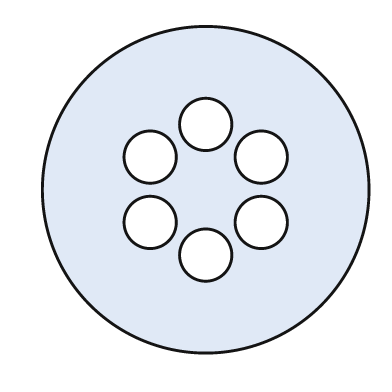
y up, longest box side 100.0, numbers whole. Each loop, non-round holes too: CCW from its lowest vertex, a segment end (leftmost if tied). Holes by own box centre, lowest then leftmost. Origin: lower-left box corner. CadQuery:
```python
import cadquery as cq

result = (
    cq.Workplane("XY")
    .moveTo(50.0, 50.0)
    .circle(50.0)
    .moveTo(50.0, 30.0)
    .circle(8.0)
    .moveTo(33.0, 40.0)
    .circle(8.0)
    .moveTo(67.0, 40.0)
    .circle(8.0)
    .moveTo(33.0, 60.0)
    .circle(8.0)
    .moveTo(67.0, 60.0)
    .circle(8.0)
    .moveTo(50.0, 70.0)
    .circle(8.0)
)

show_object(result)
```